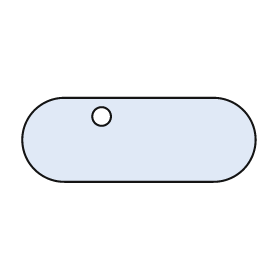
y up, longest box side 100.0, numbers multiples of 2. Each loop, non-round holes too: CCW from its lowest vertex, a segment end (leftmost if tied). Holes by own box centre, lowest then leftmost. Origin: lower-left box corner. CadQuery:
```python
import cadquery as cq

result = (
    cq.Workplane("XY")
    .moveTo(18.0, 0.0)
    .lineTo(82.0, 0.0)
    .threePointArc((100.0, 18.0), (82.0, 36.0))
    .lineTo(18.0, 36.0)
    .threePointArc((0.0, 18.0), (18.0, 0.0))
    .close()
    .moveTo(34.0, 28.0)
    .circle(4.0)
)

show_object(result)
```